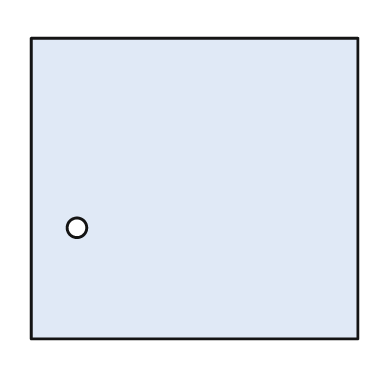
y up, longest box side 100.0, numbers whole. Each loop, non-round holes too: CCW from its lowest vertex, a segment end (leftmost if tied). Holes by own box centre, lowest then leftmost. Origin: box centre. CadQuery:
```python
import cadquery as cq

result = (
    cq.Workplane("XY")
    .moveTo(-50.0, -46.0)
    .lineTo(50.0, -46.0)
    .lineTo(50.0, 46.0)
    .lineTo(-50.0, 46.0)
    .close()
    .moveTo(-36.0, -12.0)
    .circle(3.0)
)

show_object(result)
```